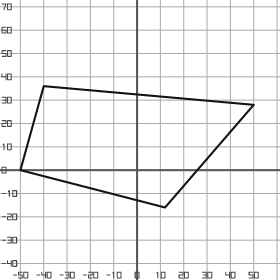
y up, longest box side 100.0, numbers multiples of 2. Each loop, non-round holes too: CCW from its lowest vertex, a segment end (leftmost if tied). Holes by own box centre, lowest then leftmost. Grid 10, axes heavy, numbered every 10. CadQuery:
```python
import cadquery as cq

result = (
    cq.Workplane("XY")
    .moveTo(12.0, -16.0)
    .lineTo(50.0, 28.0)
    .lineTo(-40.0, 36.0)
    .lineTo(-50.0, 0.0)
    .close()
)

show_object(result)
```